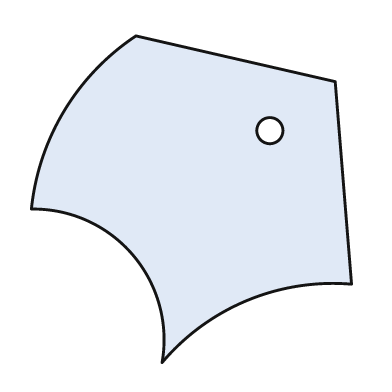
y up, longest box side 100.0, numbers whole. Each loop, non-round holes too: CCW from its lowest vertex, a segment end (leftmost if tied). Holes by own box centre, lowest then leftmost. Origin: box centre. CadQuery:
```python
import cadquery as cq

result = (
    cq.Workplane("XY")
    .moveTo(-9.0, -50.0)
    .threePointArc((17.0, -31.0), (49.0, -26.0))
    .lineTo(44.0, 36.0)
    .lineTo(-17.0, 50.0)
    .threePointArc((-39.0, 27.0), (-49.0, -3.0))
    .threePointArc((-18.0, -17.0), (-9.0, -50.0))
    .close()
    .moveTo(24.0, 21.0)
    .circle(4.0)
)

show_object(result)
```